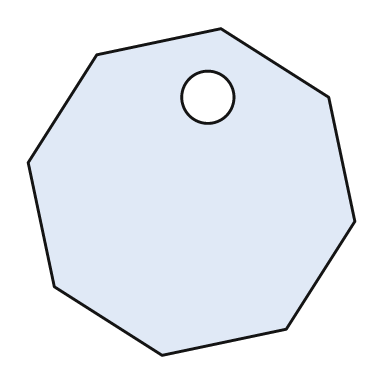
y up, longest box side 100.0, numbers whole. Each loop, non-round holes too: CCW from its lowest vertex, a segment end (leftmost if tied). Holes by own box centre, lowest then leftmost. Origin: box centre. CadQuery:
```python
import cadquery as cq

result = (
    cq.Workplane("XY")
    .moveTo(-9.0, -50.0)
    .lineTo(29.0, -42.0)
    .lineTo(50.0, -9.0)
    .lineTo(42.0, 29.0)
    .lineTo(9.0, 50.0)
    .lineTo(-29.0, 42.0)
    .lineTo(-50.0, 9.0)
    .lineTo(-42.0, -29.0)
    .close()
    .moveTo(5.0, 29.0)
    .circle(8.0)
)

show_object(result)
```